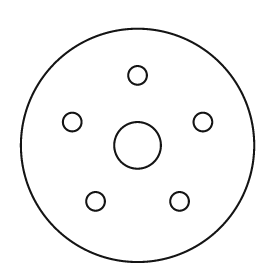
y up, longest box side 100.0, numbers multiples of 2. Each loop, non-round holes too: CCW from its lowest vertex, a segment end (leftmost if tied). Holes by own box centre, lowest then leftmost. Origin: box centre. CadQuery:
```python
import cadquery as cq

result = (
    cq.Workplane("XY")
    .moveTo(0.0, 0.0)
    .circle(50.0)
    .moveTo(-18.0, -24.0)
    .circle(4.0)
    .moveTo(18.0, -24.0)
    .circle(4.0)
    .moveTo(0.0, 0.0)
    .circle(10.0)
    .moveTo(-28.0, 10.0)
    .circle(4.0)
    .moveTo(28.0, 10.0)
    .circle(4.0)
    .moveTo(0.0, 30.0)
    .circle(4.0)
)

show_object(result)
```